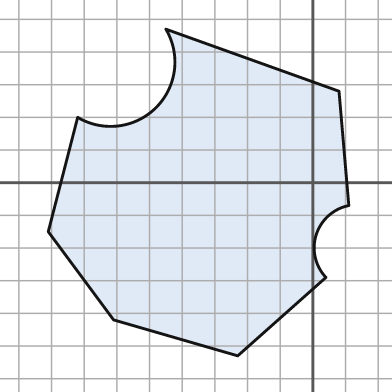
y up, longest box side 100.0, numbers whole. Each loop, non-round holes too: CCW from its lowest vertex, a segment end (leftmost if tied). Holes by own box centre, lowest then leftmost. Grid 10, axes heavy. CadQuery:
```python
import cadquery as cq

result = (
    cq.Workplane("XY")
    .moveTo(-23.0, -53.0)
    .lineTo(4.0, -29.0)
    .threePointArc((1.0, -16.0), (11.0, -7.0))
    .lineTo(8.0, 28.0)
    .lineTo(-45.0, 47.0)
    .threePointArc((-48.0, 23.0), (-72.0, 20.0))
    .lineTo(-81.0, -15.0)
    .lineTo(-61.0, -42.0)
    .close()
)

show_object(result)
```